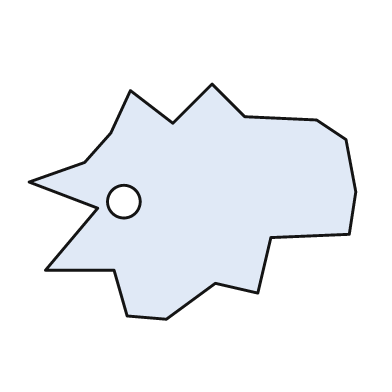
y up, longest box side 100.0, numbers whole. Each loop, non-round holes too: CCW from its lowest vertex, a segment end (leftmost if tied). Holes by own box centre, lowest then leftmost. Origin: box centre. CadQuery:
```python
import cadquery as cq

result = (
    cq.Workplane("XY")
    .moveTo(-8.0, -36.0)
    .lineTo(7.0, -25.0)
    .lineTo(20.0, -28.0)
    .lineTo(24.0, -11.0)
    .lineTo(48.0, -10.0)
    .lineTo(50.0, 3.0)
    .lineTo(47.0, 19.0)
    .lineTo(38.0, 25.0)
    .lineTo(16.0, 26.0)
    .lineTo(6.0, 36.0)
    .lineTo(-6.0, 24.0)
    .lineTo(-19.0, 34.0)
    .lineTo(-25.0, 21.0)
    .lineTo(-33.0, 12.0)
    .lineTo(-50.0, 6.0)
    .lineTo(-29.0, -2.0)
    .lineTo(-45.0, -21.0)
    .lineTo(-24.0, -21.0)
    .lineTo(-20.0, -35.0)
    .close()
    .moveTo(-21.0, 0.0)
    .circle(5.0)
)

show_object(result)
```